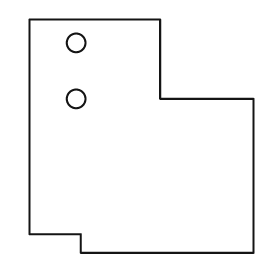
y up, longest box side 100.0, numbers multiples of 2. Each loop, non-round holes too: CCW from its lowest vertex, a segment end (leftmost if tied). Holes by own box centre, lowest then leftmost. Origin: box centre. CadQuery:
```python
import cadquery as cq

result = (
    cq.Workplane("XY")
    .moveTo(-26.0, -50.0)
    .lineTo(48.0, -50.0)
    .lineTo(48.0, 16.0)
    .lineTo(8.0, 16.0)
    .lineTo(8.0, 50.0)
    .lineTo(-48.0, 50.0)
    .lineTo(-48.0, -42.0)
    .lineTo(-26.0, -42.0)
    .close()
    .moveTo(-28.0, 16.0)
    .circle(4.0)
    .moveTo(-28.0, 40.0)
    .circle(4.0)
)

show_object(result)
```